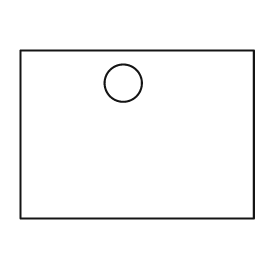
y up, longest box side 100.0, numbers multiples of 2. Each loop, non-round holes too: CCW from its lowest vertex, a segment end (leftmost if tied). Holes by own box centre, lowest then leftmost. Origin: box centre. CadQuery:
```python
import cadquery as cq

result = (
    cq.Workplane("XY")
    .moveTo(-50.0, -36.0)
    .lineTo(50.0, -36.0)
    .lineTo(50.0, 36.0)
    .lineTo(-50.0, 36.0)
    .close()
    .moveTo(-6.0, 22.0)
    .circle(8.0)
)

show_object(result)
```